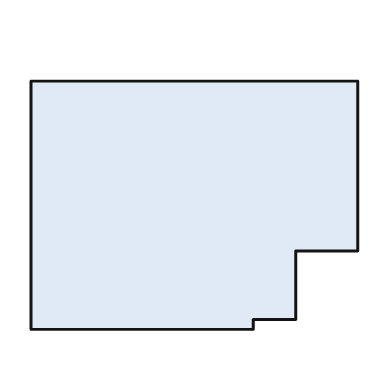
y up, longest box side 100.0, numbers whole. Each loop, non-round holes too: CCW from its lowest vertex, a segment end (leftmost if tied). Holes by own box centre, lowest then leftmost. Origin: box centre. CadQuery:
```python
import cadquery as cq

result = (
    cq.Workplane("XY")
    .moveTo(-50.0, -38.0)
    .lineTo(18.0, -38.0)
    .lineTo(18.0, -35.0)
    .lineTo(31.0, -35.0)
    .lineTo(31.0, -14.0)
    .lineTo(50.0, -14.0)
    .lineTo(50.0, 38.0)
    .lineTo(-50.0, 38.0)
    .close()
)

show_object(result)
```